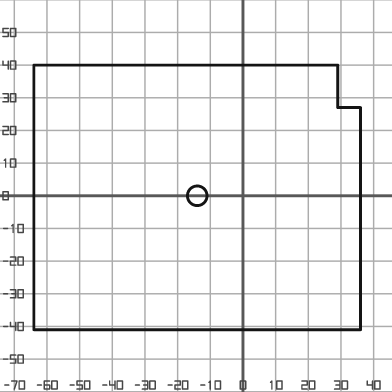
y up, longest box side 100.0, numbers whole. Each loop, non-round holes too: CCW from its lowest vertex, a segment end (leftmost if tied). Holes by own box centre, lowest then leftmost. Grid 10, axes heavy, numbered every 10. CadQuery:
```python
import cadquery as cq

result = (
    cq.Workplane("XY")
    .moveTo(-64.0, -41.0)
    .lineTo(36.0, -41.0)
    .lineTo(36.0, 27.0)
    .lineTo(29.0, 27.0)
    .lineTo(29.0, 40.0)
    .lineTo(-64.0, 40.0)
    .close()
    .moveTo(-14.0, 0.0)
    .circle(3.0)
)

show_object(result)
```